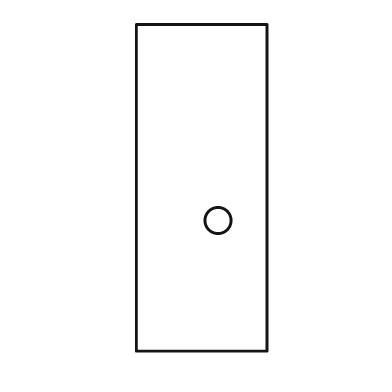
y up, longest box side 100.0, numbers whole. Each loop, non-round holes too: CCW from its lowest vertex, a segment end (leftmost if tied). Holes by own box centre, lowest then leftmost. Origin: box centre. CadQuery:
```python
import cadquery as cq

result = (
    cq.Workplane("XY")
    .moveTo(-20.0, -50.0)
    .lineTo(20.0, -50.0)
    .lineTo(20.0, 50.0)
    .lineTo(-20.0, 50.0)
    .close()
    .moveTo(5.0, -10.0)
    .circle(4.0)
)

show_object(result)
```